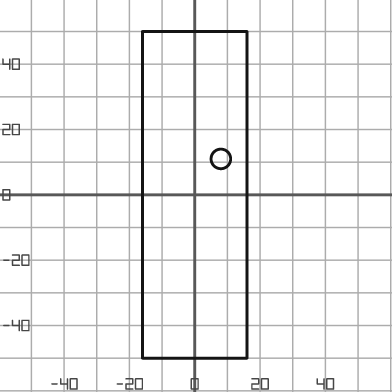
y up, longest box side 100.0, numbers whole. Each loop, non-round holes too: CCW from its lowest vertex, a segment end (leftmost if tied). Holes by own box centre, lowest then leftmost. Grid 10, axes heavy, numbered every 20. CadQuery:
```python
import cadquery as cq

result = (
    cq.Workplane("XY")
    .moveTo(-16.0, -50.0)
    .lineTo(16.0, -50.0)
    .lineTo(16.0, 50.0)
    .lineTo(-16.0, 50.0)
    .close()
    .moveTo(8.0, 11.0)
    .circle(3.0)
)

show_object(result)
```